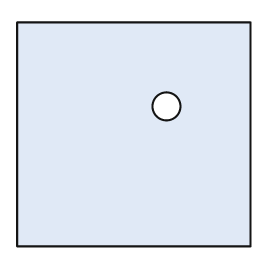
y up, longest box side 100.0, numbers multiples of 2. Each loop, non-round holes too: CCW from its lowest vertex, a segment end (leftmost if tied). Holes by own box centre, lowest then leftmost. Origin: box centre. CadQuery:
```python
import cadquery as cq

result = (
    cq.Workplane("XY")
    .moveTo(-50.0, -48.0)
    .lineTo(50.0, -48.0)
    .lineTo(50.0, 48.0)
    .lineTo(-50.0, 48.0)
    .close()
    .moveTo(14.0, 12.0)
    .circle(6.0)
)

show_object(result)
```